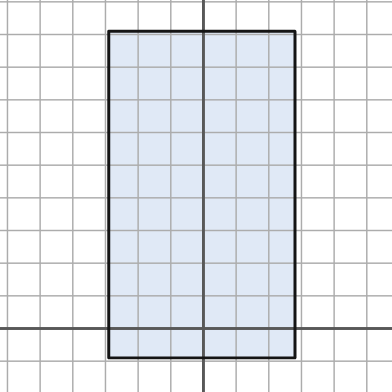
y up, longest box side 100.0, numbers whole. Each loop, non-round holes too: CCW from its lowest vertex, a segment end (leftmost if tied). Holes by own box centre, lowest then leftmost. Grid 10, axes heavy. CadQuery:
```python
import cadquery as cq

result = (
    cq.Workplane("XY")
    .moveTo(-29.0, -9.0)
    .lineTo(28.0, -9.0)
    .lineTo(28.0, 91.0)
    .lineTo(-29.0, 91.0)
    .close()
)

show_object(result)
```